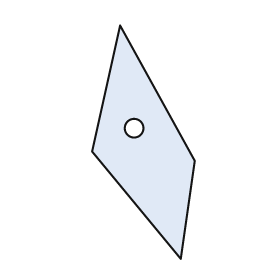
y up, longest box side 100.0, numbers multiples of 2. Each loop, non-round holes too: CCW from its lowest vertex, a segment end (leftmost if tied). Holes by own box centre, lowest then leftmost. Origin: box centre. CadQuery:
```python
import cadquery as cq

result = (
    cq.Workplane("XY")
    .moveTo(16.0, -50.0)
    .lineTo(22.0, -8.0)
    .lineTo(-10.0, 50.0)
    .lineTo(-22.0, -4.0)
    .close()
    .moveTo(-4.0, 6.0)
    .circle(4.0)
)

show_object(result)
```